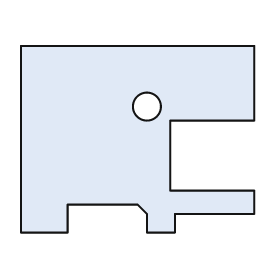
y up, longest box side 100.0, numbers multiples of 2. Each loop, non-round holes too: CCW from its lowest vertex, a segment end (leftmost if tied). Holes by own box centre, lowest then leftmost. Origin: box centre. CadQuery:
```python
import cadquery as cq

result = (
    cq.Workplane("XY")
    .moveTo(-50.0, -40.0)
    .lineTo(-30.0, -40.0)
    .lineTo(-30.0, -28.0)
    .lineTo(0.0, -28.0)
    .lineTo(4.0, -32.0)
    .lineTo(4.0, -40.0)
    .lineTo(16.0, -40.0)
    .lineTo(16.0, -32.0)
    .lineTo(50.0, -32.0)
    .lineTo(50.0, -22.0)
    .lineTo(14.0, -22.0)
    .lineTo(14.0, 8.0)
    .lineTo(50.0, 8.0)
    .lineTo(50.0, 40.0)
    .lineTo(-50.0, 40.0)
    .close()
    .moveTo(4.0, 14.0)
    .circle(6.0)
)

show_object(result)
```